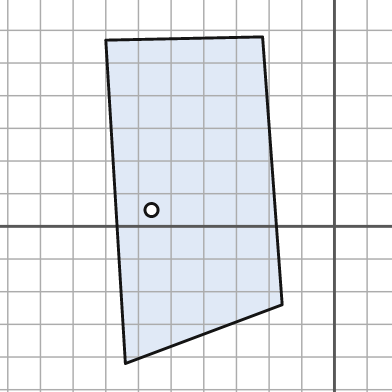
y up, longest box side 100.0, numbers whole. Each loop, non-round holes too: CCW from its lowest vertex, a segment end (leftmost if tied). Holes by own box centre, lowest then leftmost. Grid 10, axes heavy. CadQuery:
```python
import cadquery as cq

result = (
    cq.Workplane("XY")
    .moveTo(-64.0, -42.0)
    .lineTo(-16.0, -24.0)
    .lineTo(-22.0, 58.0)
    .lineTo(-70.0, 57.0)
    .close()
    .moveTo(-56.0, 5.0)
    .circle(2.0)
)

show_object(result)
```